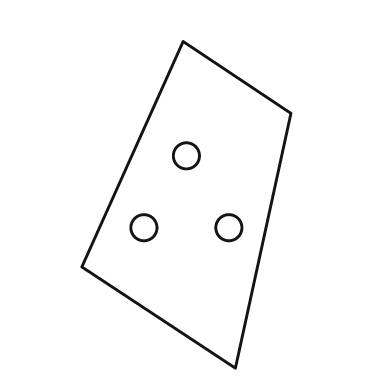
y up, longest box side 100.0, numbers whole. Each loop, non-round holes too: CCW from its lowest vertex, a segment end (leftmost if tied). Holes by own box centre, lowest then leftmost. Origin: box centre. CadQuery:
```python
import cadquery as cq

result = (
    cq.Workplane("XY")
    .moveTo(15.0, -50.0)
    .lineTo(32.0, 28.0)
    .lineTo(-1.0, 50.0)
    .lineTo(-32.0, -19.0)
    .close()
    .moveTo(-13.0, -7.0)
    .circle(4.0)
    .moveTo(13.0, -7.0)
    .circle(4.0)
    .moveTo(0.0, 15.0)
    .circle(4.0)
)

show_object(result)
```